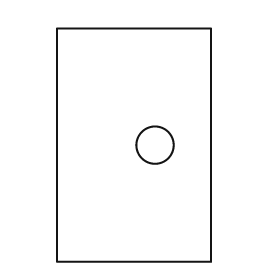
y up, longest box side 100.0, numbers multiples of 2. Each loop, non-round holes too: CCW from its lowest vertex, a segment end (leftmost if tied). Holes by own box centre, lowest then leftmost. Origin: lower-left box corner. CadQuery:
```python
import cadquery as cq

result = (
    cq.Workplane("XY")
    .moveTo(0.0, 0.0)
    .lineTo(66.0, 0.0)
    .lineTo(66.0, 100.0)
    .lineTo(0.0, 100.0)
    .close()
    .moveTo(42.0, 50.0)
    .circle(8.0)
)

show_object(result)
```